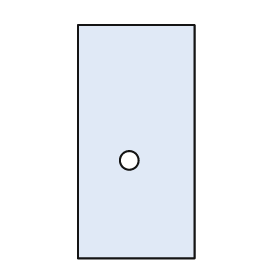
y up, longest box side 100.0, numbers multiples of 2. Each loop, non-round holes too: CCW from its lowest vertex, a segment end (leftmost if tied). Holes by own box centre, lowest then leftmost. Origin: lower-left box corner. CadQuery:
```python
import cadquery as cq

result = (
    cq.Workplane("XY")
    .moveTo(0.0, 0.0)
    .lineTo(50.0, 0.0)
    .lineTo(50.0, 100.0)
    .lineTo(0.0, 100.0)
    .close()
    .moveTo(22.0, 42.0)
    .circle(4.0)
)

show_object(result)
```